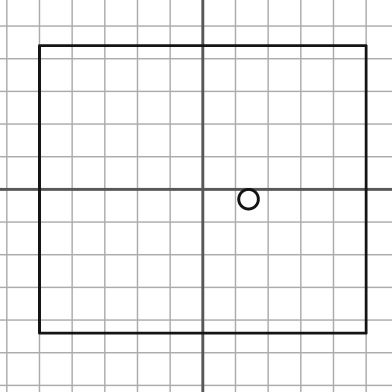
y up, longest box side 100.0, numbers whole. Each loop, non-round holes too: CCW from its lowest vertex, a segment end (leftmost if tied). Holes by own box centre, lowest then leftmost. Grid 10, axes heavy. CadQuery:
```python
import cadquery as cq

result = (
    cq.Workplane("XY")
    .moveTo(-50.0, -44.0)
    .lineTo(50.0, -44.0)
    .lineTo(50.0, 44.0)
    .lineTo(-50.0, 44.0)
    .close()
    .moveTo(14.0, -3.0)
    .circle(3.0)
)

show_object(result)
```